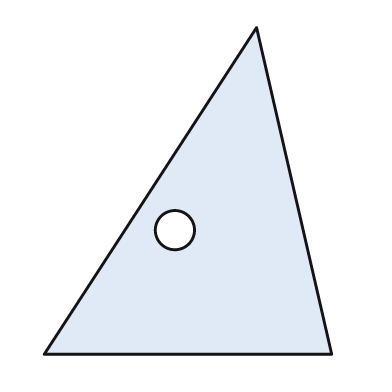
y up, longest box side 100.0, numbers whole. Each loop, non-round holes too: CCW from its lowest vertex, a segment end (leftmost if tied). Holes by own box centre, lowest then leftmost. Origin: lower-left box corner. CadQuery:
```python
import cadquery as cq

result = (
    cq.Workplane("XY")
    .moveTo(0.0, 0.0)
    .lineTo(88.0, 0.0)
    .lineTo(65.0, 100.0)
    .close()
    .moveTo(40.0, 38.0)
    .circle(6.0)
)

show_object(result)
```